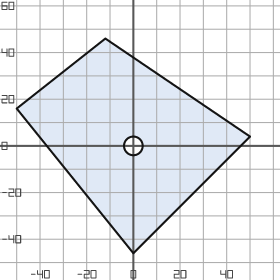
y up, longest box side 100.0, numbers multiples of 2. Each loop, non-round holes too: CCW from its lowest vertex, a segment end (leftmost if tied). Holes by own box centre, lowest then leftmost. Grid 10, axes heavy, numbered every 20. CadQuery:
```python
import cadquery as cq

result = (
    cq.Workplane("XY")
    .moveTo(0.0, -46.0)
    .lineTo(50.0, 4.0)
    .lineTo(-12.0, 46.0)
    .lineTo(-50.0, 16.0)
    .close()
    .moveTo(0.0, 0.0)
    .circle(4.0)
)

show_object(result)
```